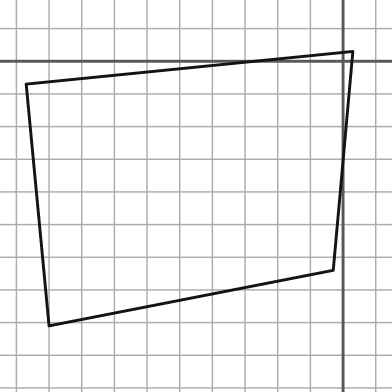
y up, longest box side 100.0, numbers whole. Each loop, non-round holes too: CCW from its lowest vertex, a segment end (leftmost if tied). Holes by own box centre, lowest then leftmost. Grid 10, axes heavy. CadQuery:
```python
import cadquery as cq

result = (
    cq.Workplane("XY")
    .moveTo(-90.0, -81.0)
    .lineTo(-3.0, -64.0)
    .lineTo(3.0, 3.0)
    .lineTo(-97.0, -7.0)
    .close()
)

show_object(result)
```